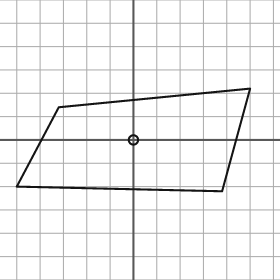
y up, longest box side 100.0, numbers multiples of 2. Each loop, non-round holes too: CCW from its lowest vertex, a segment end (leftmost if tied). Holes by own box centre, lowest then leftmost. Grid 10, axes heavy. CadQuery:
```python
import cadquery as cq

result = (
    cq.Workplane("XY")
    .moveTo(38.0, -22.0)
    .lineTo(50.0, 22.0)
    .lineTo(-32.0, 14.0)
    .lineTo(-50.0, -20.0)
    .close()
    .moveTo(0.0, 0.0)
    .circle(2.0)
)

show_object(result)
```